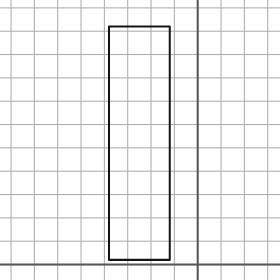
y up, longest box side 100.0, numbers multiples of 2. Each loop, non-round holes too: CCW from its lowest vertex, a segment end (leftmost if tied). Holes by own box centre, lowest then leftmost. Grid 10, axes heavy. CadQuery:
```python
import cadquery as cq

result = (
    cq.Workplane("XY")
    .moveTo(-38.0, 2.0)
    .lineTo(-12.0, 2.0)
    .lineTo(-12.0, 102.0)
    .lineTo(-38.0, 102.0)
    .close()
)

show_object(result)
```